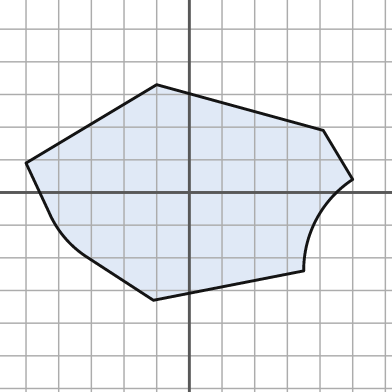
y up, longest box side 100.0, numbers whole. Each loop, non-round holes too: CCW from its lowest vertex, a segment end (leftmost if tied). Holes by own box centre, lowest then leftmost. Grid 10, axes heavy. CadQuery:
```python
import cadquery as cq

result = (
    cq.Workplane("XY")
    .moveTo(-11.0, -33.0)
    .lineTo(35.0, -24.0)
    .threePointArc((39.0, -8.0), (50.0, 4.0))
    .lineTo(41.0, 19.0)
    .lineTo(-10.0, 33.0)
    .lineTo(-50.0, 9.0)
    .lineTo(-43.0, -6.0)
    .threePointArc((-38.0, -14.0), (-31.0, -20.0))
    .close()
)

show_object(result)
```